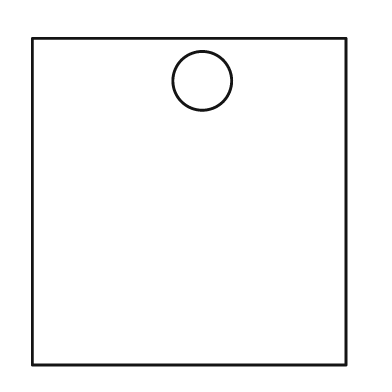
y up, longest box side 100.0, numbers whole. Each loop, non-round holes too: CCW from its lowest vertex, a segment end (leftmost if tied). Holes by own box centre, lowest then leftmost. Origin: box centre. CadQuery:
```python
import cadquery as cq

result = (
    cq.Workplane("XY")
    .moveTo(-48.0, -50.0)
    .lineTo(48.0, -50.0)
    .lineTo(48.0, 50.0)
    .lineTo(-48.0, 50.0)
    .close()
    .moveTo(4.0, 37.0)
    .circle(9.0)
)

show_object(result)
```